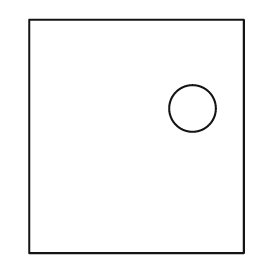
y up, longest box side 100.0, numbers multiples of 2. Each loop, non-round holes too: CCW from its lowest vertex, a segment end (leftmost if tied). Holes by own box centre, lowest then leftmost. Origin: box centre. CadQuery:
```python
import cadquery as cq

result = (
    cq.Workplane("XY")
    .moveTo(-46.0, -50.0)
    .lineTo(46.0, -50.0)
    .lineTo(46.0, 50.0)
    .lineTo(-46.0, 50.0)
    .close()
    .moveTo(24.0, 12.0)
    .circle(10.0)
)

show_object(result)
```